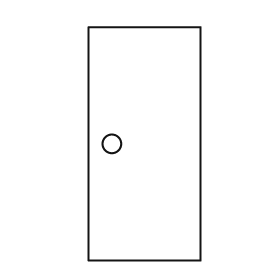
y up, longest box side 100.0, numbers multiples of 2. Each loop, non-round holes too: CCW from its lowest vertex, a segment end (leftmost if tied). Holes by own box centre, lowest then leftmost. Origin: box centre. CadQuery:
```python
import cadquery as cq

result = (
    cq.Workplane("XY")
    .moveTo(-24.0, -50.0)
    .lineTo(24.0, -50.0)
    .lineTo(24.0, 50.0)
    .lineTo(-24.0, 50.0)
    .close()
    .moveTo(-14.0, 0.0)
    .circle(4.0)
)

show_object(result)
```